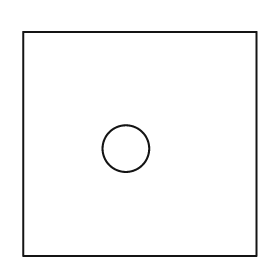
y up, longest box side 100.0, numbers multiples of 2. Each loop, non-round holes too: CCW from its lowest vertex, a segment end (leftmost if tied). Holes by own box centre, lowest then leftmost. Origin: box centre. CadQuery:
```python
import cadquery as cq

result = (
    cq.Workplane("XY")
    .moveTo(-50.0, -48.0)
    .lineTo(50.0, -48.0)
    .lineTo(50.0, 48.0)
    .lineTo(-50.0, 48.0)
    .close()
    .moveTo(-6.0, -2.0)
    .circle(10.0)
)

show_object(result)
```